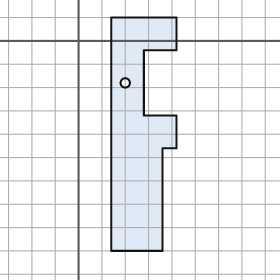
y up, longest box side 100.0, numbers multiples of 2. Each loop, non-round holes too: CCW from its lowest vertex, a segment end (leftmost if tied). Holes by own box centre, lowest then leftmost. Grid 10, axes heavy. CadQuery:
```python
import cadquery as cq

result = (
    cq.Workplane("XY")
    .moveTo(14.0, -90.0)
    .lineTo(36.0, -90.0)
    .lineTo(36.0, -46.0)
    .lineTo(42.0, -46.0)
    .lineTo(42.0, -32.0)
    .lineTo(28.0, -32.0)
    .lineTo(28.0, -4.0)
    .lineTo(42.0, -4.0)
    .lineTo(42.0, 10.0)
    .lineTo(14.0, 10.0)
    .close()
    .moveTo(20.0, -18.0)
    .circle(2.0)
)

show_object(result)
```